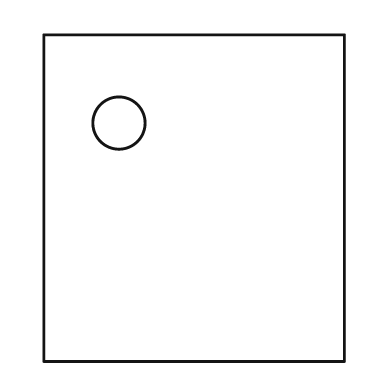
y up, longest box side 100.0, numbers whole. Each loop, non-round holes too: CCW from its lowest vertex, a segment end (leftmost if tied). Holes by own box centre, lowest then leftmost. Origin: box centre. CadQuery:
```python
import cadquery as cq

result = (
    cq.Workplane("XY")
    .moveTo(-46.0, -50.0)
    .lineTo(46.0, -50.0)
    .lineTo(46.0, 50.0)
    .lineTo(-46.0, 50.0)
    .close()
    .moveTo(-23.0, 23.0)
    .circle(8.0)
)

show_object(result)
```